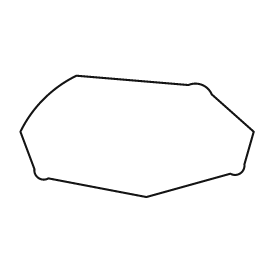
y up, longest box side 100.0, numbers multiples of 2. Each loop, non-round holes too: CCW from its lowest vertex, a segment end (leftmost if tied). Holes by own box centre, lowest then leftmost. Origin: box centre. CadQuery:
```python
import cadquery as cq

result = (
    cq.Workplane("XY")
    .moveTo(4.0, -26.0)
    .lineTo(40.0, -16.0)
    .threePointArc((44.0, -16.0), (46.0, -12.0))
    .lineTo(50.0, 2.0)
    .lineTo(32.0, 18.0)
    .threePointArc((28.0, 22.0), (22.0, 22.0))
    .lineTo(-26.0, 26.0)
    .threePointArc((-40.0, 16.0), (-50.0, 2.0))
    .lineTo(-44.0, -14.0)
    .threePointArc((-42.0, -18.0), (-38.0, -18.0))
    .close()
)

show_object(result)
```